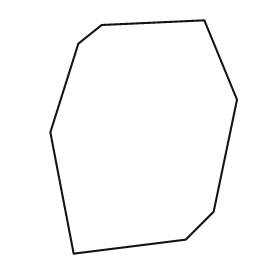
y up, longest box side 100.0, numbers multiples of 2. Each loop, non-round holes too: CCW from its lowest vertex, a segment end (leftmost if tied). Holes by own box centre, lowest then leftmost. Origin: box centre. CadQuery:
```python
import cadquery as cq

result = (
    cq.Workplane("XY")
    .moveTo(-30.0, -50.0)
    .lineTo(18.0, -44.0)
    .lineTo(30.0, -32.0)
    .lineTo(40.0, 16.0)
    .lineTo(26.0, 50.0)
    .lineTo(-18.0, 48.0)
    .lineTo(-28.0, 40.0)
    .lineTo(-40.0, 2.0)
    .close()
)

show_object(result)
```